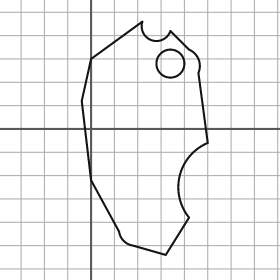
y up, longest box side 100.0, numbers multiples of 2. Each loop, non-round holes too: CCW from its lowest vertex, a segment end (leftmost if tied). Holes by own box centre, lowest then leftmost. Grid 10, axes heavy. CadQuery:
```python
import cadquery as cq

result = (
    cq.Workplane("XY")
    .moveTo(32.0, -54.0)
    .lineTo(42.0, -38.0)
    .threePointArc((38.0, -20.0), (50.0, -6.0))
    .lineTo(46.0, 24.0)
    .threePointArc((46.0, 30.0), (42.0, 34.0))
    .lineTo(34.0, 42.0)
    .threePointArc((26.0, 38.0), (22.0, 46.0))
    .lineTo(0.0, 30.0)
    .lineTo(-4.0, 12.0)
    .lineTo(0.0, -22.0)
    .lineTo(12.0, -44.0)
    .threePointArc((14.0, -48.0), (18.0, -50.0))
    .close()
    .moveTo(34.0, 28.0)
    .circle(6.0)
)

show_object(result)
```